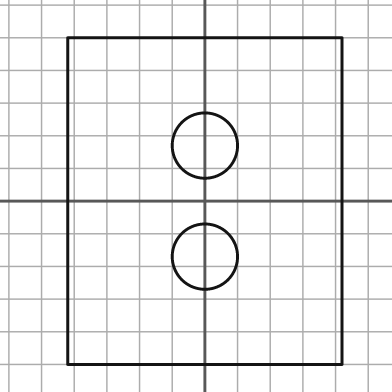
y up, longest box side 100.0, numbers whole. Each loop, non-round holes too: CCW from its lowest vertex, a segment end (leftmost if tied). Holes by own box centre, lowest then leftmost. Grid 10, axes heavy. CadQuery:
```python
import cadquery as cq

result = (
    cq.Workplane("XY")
    .moveTo(-42.0, -50.0)
    .lineTo(42.0, -50.0)
    .lineTo(42.0, 50.0)
    .lineTo(-42.0, 50.0)
    .close()
    .moveTo(0.0, -17.0)
    .circle(10.0)
    .moveTo(0.0, 17.0)
    .circle(10.0)
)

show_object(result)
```